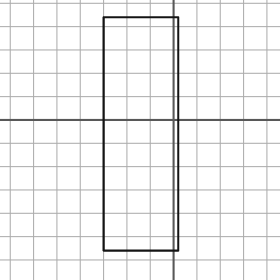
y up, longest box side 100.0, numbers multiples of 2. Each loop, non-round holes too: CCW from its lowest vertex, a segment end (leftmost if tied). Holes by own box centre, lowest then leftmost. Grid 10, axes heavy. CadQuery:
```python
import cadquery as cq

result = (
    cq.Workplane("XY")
    .moveTo(-30.0, -56.0)
    .lineTo(2.0, -56.0)
    .lineTo(2.0, 44.0)
    .lineTo(-30.0, 44.0)
    .close()
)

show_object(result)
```